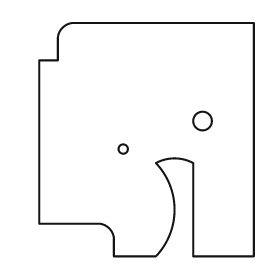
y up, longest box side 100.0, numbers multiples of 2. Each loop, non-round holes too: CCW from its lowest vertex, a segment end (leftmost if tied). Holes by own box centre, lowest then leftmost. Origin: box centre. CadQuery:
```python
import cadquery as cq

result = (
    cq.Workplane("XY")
    .moveTo(-14.0, -50.0)
    .lineTo(4.0, -50.0)
    .threePointArc((12.0, -30.0), (4.0, -10.0))
    .threePointArc((12.0, -8.0), (20.0, -10.0))
    .lineTo(20.0, -50.0)
    .lineTo(46.0, -50.0)
    .lineTo(46.0, 50.0)
    .lineTo(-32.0, 50.0)
    .threePointArc((-36.0, 48.0), (-38.0, 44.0))
    .lineTo(-38.0, 34.0)
    .lineTo(-46.0, 34.0)
    .lineTo(-46.0, -36.0)
    .lineTo(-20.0, -36.0)
    .threePointArc((-16.0, -38.0), (-14.0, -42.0))
    .close()
    .moveTo(-10.0, -4.0)
    .circle(2.0)
    .moveTo(24.0, 8.0)
    .circle(4.0)
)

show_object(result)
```